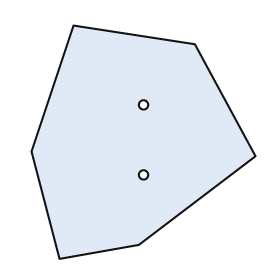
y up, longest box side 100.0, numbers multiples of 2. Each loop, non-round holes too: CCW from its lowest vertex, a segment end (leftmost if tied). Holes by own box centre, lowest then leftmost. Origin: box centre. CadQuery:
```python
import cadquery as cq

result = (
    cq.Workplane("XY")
    .moveTo(-36.0, -50.0)
    .lineTo(-2.0, -44.0)
    .lineTo(48.0, -6.0)
    .lineTo(22.0, 42.0)
    .lineTo(-30.0, 50.0)
    .lineTo(-48.0, -4.0)
    .close()
    .moveTo(0.0, -14.0)
    .circle(2.0)
    .moveTo(0.0, 16.0)
    .circle(2.0)
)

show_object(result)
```